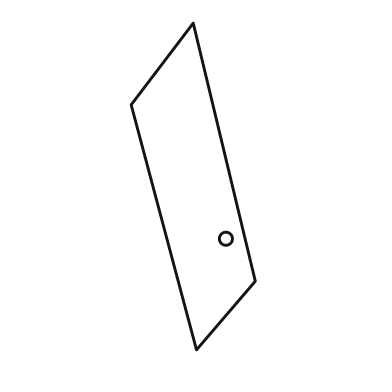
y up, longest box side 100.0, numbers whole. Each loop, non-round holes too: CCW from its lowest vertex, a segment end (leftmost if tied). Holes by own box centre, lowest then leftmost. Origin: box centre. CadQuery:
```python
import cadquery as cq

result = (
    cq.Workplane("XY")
    .moveTo(1.0, -50.0)
    .lineTo(19.0, -29.0)
    .lineTo(0.0, 50.0)
    .lineTo(-19.0, 25.0)
    .close()
    .moveTo(10.0, -16.0)
    .circle(2.0)
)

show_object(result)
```